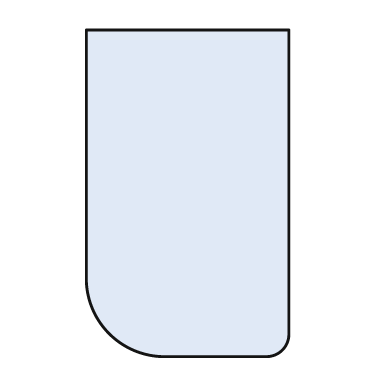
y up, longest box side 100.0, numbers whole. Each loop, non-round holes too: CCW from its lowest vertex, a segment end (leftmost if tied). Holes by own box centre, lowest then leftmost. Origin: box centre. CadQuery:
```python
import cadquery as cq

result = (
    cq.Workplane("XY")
    .moveTo(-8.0, -50.0)
    .lineTo(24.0, -50.0)
    .threePointArc((29.0, -48.0), (31.0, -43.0))
    .lineTo(31.0, 50.0)
    .lineTo(-31.0, 50.0)
    .lineTo(-31.0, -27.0)
    .threePointArc((-24.0, -43.0), (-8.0, -50.0))
    .close()
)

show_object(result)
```